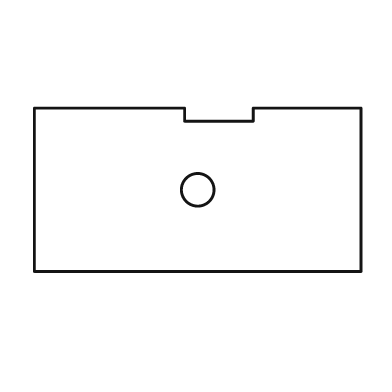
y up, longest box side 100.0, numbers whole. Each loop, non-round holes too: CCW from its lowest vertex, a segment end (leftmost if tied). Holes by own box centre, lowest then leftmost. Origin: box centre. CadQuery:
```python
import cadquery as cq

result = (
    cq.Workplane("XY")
    .moveTo(-50.0, -25.0)
    .lineTo(50.0, -25.0)
    .lineTo(50.0, 25.0)
    .lineTo(17.0, 25.0)
    .lineTo(17.0, 21.0)
    .lineTo(-4.0, 21.0)
    .lineTo(-4.0, 25.0)
    .lineTo(-50.0, 25.0)
    .close()
    .moveTo(0.0, 0.0)
    .circle(5.0)
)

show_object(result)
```